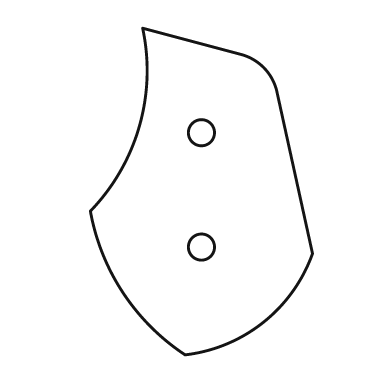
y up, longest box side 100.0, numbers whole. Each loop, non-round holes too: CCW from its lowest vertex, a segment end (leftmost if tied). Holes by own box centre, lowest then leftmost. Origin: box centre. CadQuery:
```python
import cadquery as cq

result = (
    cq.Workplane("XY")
    .moveTo(-5.0, -50.0)
    .threePointArc((19.0, -40.0), (34.0, -19.0))
    .lineTo(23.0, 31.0)
    .threePointArc((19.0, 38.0), (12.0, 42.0))
    .lineTo(-18.0, 50.0)
    .threePointArc((-19.0, 20.0), (-34.0, -6.0))
    .threePointArc((-24.0, -31.0), (-5.0, -50.0))
    .close()
    .moveTo(0.0, -17.0)
    .circle(4.0)
    .moveTo(0.0, 18.0)
    .circle(4.0)
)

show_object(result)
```